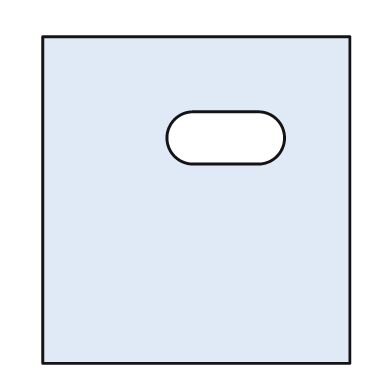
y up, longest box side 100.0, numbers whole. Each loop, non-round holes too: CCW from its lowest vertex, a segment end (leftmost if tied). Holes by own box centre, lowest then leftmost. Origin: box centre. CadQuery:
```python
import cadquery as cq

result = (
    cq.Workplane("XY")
    .moveTo(-47.0, -50.0)
    .lineTo(47.0, -50.0)
    .lineTo(47.0, 50.0)
    .lineTo(-47.0, 50.0)
    .close()
    .moveTo(-1.0, 11.0)
    .lineTo(19.0, 11.0)
    .threePointArc((27.0, 19.0), (19.0, 27.0))
    .lineTo(-1.0, 27.0)
    .threePointArc((-9.0, 19.0), (-1.0, 11.0))
    .close()
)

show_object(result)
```